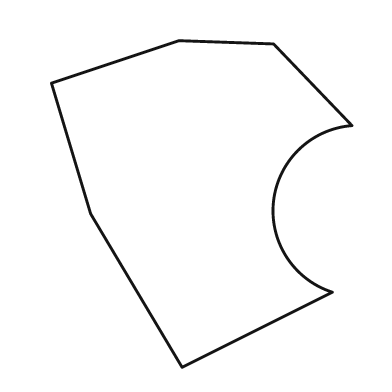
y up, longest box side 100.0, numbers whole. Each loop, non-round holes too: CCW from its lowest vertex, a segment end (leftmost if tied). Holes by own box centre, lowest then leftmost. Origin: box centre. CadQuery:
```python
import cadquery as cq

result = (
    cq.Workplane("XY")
    .moveTo(-6.0, -50.0)
    .lineTo(40.0, -27.0)
    .threePointArc((22.0, 1.0), (46.0, 24.0))
    .lineTo(22.0, 49.0)
    .lineTo(-7.0, 50.0)
    .lineTo(-46.0, 37.0)
    .lineTo(-34.0, -3.0)
    .close()
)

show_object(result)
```